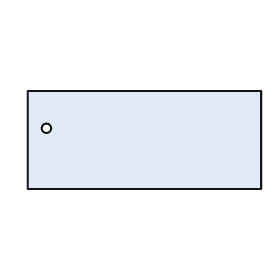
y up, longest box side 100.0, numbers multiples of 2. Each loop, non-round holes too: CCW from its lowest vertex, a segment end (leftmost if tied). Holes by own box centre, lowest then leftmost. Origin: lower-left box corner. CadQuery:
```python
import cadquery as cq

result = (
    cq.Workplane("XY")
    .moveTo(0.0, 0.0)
    .lineTo(100.0, 0.0)
    .lineTo(100.0, 42.0)
    .lineTo(0.0, 42.0)
    .close()
    .moveTo(8.0, 26.0)
    .circle(2.0)
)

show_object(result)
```